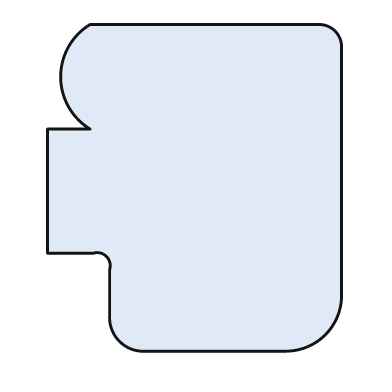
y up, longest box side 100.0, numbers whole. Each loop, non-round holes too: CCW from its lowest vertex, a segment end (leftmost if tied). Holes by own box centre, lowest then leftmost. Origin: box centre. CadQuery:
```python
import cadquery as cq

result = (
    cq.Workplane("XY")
    .moveTo(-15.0, -50.0)
    .lineTo(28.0, -50.0)
    .threePointArc((40.0, -45.0), (45.0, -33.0))
    .lineTo(45.0, 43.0)
    .threePointArc((43.0, 48.0), (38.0, 50.0))
    .lineTo(-32.0, 50.0)
    .threePointArc((-41.0, 34.0), (-32.0, 18.0))
    .lineTo(-45.0, 18.0)
    .lineTo(-45.0, -20.0)
    .lineTo(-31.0, -20.0)
    .threePointArc((-27.0, -21.0), (-26.0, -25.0))
    .lineTo(-26.0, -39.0)
    .threePointArc((-23.0, -47.0), (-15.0, -50.0))
    .close()
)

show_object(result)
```